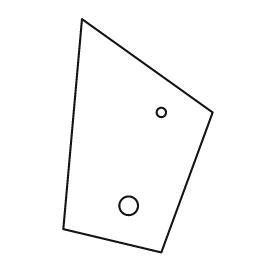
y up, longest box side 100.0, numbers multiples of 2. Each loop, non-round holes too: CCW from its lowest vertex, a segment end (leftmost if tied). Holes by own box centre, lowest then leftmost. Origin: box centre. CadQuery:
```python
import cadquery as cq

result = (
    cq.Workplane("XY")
    .moveTo(10.0, -50.0)
    .lineTo(32.0, 10.0)
    .lineTo(-24.0, 50.0)
    .lineTo(-32.0, -40.0)
    .close()
    .moveTo(-4.0, -30.0)
    .circle(4.0)
    .moveTo(10.0, 10.0)
    .circle(2.0)
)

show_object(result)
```